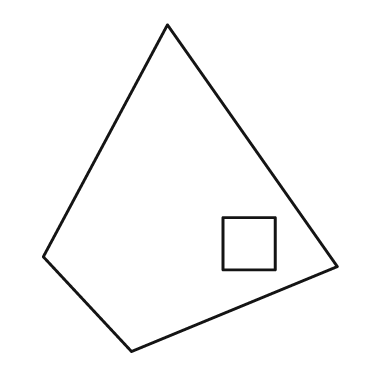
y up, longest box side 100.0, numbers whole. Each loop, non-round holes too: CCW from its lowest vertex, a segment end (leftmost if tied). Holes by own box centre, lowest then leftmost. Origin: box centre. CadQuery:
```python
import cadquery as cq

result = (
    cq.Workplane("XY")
    .moveTo(-18.0, -50.0)
    .lineTo(45.0, -24.0)
    .lineTo(-7.0, 50.0)
    .lineTo(-45.0, -21.0)
    .close()
    .moveTo(10.0, -25.0)
    .lineTo(26.0, -25.0)
    .lineTo(26.0, -9.0)
    .lineTo(10.0, -9.0)
    .close()
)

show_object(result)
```